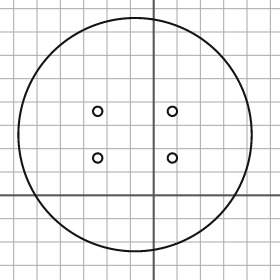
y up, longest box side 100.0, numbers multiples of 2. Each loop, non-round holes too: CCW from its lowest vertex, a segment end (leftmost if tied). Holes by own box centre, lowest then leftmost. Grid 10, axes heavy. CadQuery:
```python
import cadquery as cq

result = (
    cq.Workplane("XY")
    .moveTo(-8.0, 26.0)
    .circle(50.0)
    .moveTo(-24.0, 16.0)
    .circle(2.0)
    .moveTo(8.0, 16.0)
    .circle(2.0)
    .moveTo(-24.0, 36.0)
    .circle(2.0)
    .moveTo(8.0, 36.0)
    .circle(2.0)
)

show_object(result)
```